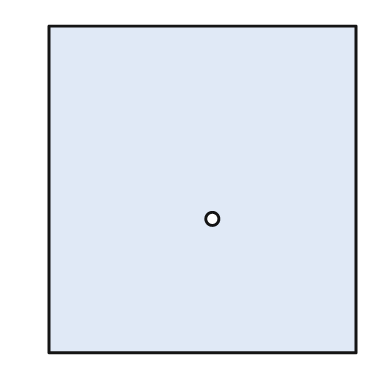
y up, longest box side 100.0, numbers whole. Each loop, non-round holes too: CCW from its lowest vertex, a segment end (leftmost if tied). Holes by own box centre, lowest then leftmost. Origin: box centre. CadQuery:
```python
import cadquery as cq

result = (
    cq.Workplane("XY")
    .moveTo(-47.0, -50.0)
    .lineTo(47.0, -50.0)
    .lineTo(47.0, 50.0)
    .lineTo(-47.0, 50.0)
    .close()
    .moveTo(3.0, -9.0)
    .circle(2.0)
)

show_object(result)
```